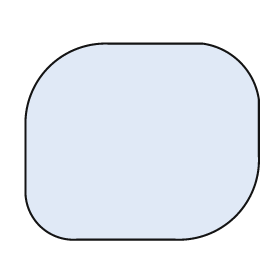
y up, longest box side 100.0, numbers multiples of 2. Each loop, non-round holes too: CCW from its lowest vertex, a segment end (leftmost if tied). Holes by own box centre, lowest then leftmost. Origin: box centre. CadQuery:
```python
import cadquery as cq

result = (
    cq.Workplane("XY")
    .moveTo(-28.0, -42.0)
    .lineTo(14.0, -42.0)
    .threePointArc((40.0, -32.0), (50.0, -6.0))
    .lineTo(50.0, 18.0)
    .threePointArc((42.0, 34.0), (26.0, 42.0))
    .lineTo(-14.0, 42.0)
    .threePointArc((-40.0, 32.0), (-50.0, 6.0))
    .lineTo(-50.0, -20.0)
    .threePointArc((-44.0, -36.0), (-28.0, -42.0))
    .close()
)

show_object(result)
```